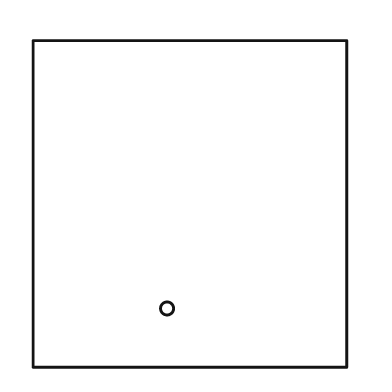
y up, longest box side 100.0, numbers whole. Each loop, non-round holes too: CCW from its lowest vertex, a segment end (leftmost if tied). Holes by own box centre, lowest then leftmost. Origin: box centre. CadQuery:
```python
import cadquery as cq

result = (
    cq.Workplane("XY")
    .moveTo(-48.0, -50.0)
    .lineTo(48.0, -50.0)
    .lineTo(48.0, 50.0)
    .lineTo(-48.0, 50.0)
    .close()
    .moveTo(-7.0, -32.0)
    .circle(2.0)
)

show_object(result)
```